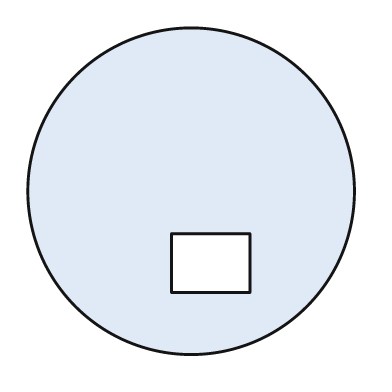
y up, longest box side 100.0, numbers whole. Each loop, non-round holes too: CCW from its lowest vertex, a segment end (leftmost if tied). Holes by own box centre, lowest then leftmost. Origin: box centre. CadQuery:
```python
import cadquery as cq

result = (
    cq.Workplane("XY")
    .moveTo(0.0, 0.0)
    .circle(50.0)
    .moveTo(-6.0, -31.0)
    .lineTo(18.0, -31.0)
    .lineTo(18.0, -13.0)
    .lineTo(-6.0, -13.0)
    .close()
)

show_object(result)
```